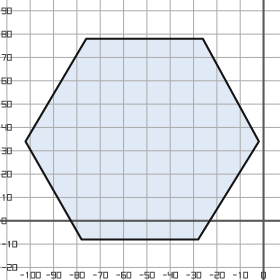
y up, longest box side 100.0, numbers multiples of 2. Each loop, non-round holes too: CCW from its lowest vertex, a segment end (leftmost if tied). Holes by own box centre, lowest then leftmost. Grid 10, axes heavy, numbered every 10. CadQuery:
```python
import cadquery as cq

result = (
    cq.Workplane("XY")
    .moveTo(-78.0, -8.0)
    .lineTo(-28.0, -8.0)
    .lineTo(-2.0, 34.0)
    .lineTo(-26.0, 78.0)
    .lineTo(-76.0, 78.0)
    .lineTo(-102.0, 34.0)
    .close()
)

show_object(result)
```